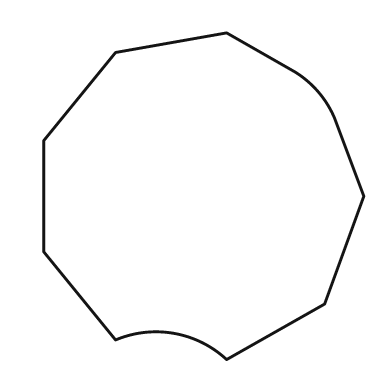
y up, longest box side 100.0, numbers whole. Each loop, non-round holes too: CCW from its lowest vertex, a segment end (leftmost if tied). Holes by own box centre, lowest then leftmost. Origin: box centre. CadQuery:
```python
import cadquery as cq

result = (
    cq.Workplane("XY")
    .moveTo(7.0, -50.0)
    .lineTo(37.0, -33.0)
    .lineTo(49.0, 0.0)
    .lineTo(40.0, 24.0)
    .threePointArc((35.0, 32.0), (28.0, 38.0))
    .lineTo(7.0, 50.0)
    .lineTo(-27.0, 44.0)
    .lineTo(-49.0, 17.0)
    .lineTo(-49.0, -17.0)
    .lineTo(-27.0, -44.0)
    .threePointArc((-9.0, -42.0), (7.0, -50.0))
    .close()
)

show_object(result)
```